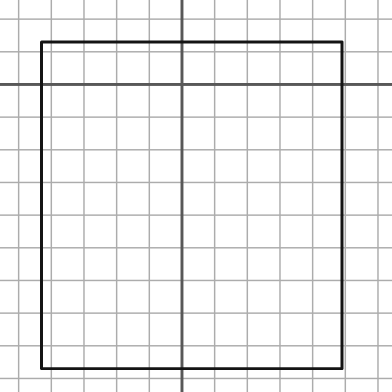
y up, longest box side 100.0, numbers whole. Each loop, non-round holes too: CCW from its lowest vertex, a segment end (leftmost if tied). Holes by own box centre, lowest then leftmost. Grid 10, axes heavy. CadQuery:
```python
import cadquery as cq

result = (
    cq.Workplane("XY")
    .moveTo(-43.0, -87.0)
    .lineTo(49.0, -87.0)
    .lineTo(49.0, 13.0)
    .lineTo(-43.0, 13.0)
    .close()
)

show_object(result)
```